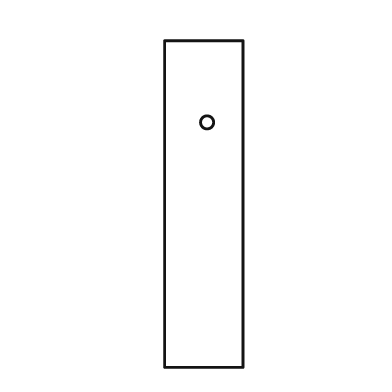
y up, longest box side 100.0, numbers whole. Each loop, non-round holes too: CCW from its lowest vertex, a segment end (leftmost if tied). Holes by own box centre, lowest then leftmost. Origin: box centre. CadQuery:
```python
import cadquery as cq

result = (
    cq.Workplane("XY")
    .moveTo(-12.0, -50.0)
    .lineTo(12.0, -50.0)
    .lineTo(12.0, 50.0)
    .lineTo(-12.0, 50.0)
    .close()
    .moveTo(1.0, 25.0)
    .circle(2.0)
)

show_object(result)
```